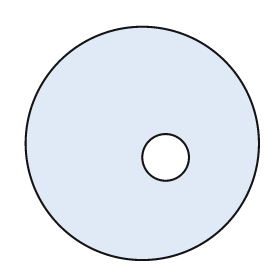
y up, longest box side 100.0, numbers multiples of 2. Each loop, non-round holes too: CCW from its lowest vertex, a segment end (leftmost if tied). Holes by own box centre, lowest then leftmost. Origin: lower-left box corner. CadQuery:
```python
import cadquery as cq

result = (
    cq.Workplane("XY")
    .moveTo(50.0, 50.0)
    .circle(50.0)
    .moveTo(60.0, 44.0)
    .circle(10.0)
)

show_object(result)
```